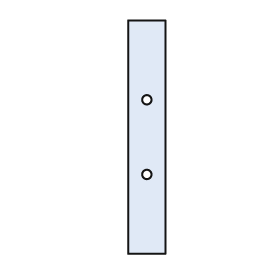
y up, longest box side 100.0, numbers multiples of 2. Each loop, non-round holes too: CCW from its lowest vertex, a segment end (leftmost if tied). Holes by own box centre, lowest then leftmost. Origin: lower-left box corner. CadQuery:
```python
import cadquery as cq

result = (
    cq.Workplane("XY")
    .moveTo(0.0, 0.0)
    .lineTo(16.0, 0.0)
    .lineTo(16.0, 100.0)
    .lineTo(0.0, 100.0)
    .close()
    .moveTo(8.0, 34.0)
    .circle(2.0)
    .moveTo(8.0, 66.0)
    .circle(2.0)
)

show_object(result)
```